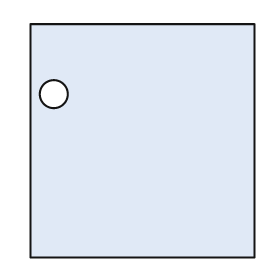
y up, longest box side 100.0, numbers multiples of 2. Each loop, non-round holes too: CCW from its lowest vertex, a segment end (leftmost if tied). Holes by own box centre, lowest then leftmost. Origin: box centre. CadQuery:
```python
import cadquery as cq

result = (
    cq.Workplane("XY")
    .moveTo(-48.0, -50.0)
    .lineTo(48.0, -50.0)
    .lineTo(48.0, 50.0)
    .lineTo(-48.0, 50.0)
    .close()
    .moveTo(-38.0, 20.0)
    .circle(6.0)
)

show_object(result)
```